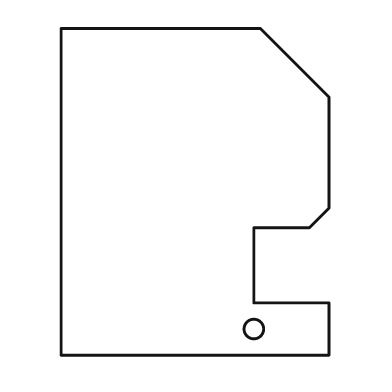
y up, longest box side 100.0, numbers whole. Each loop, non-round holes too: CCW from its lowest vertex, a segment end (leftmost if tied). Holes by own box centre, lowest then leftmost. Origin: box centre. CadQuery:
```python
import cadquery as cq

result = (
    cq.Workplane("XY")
    .moveTo(-41.0, -50.0)
    .lineTo(41.0, -50.0)
    .lineTo(41.0, -34.0)
    .lineTo(18.0, -34.0)
    .lineTo(18.0, -11.0)
    .lineTo(35.0, -11.0)
    .lineTo(41.0, -5.0)
    .lineTo(41.0, 29.0)
    .lineTo(20.0, 50.0)
    .lineTo(-41.0, 50.0)
    .close()
    .moveTo(18.0, -42.0)
    .circle(3.0)
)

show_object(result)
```